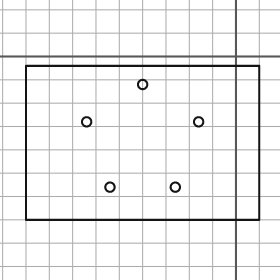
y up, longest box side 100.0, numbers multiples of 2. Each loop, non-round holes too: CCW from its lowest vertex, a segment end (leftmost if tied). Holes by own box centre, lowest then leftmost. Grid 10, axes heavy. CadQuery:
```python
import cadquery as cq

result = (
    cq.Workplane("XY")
    .moveTo(-90.0, -70.0)
    .lineTo(10.0, -70.0)
    .lineTo(10.0, -4.0)
    .lineTo(-90.0, -4.0)
    .close()
    .moveTo(-54.0, -56.0)
    .circle(2.0)
    .moveTo(-26.0, -56.0)
    .circle(2.0)
    .moveTo(-64.0, -28.0)
    .circle(2.0)
    .moveTo(-16.0, -28.0)
    .circle(2.0)
    .moveTo(-40.0, -12.0)
    .circle(2.0)
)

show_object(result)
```